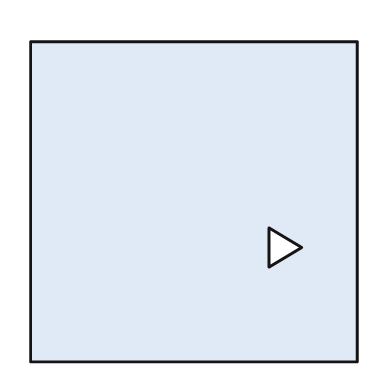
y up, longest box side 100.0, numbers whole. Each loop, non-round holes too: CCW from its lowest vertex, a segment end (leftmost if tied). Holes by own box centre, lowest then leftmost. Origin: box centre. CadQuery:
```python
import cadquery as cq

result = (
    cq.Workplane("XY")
    .moveTo(-50.0, -49.0)
    .lineTo(50.0, -49.0)
    .lineTo(50.0, 49.0)
    .lineTo(-50.0, 49.0)
    .close()
    .moveTo(23.0, -20.0)
    .lineTo(33.0, -14.0)
    .lineTo(23.0, -8.0)
    .close()
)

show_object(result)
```